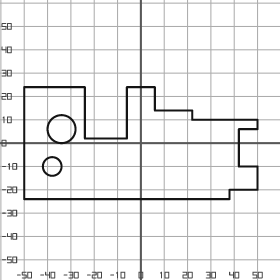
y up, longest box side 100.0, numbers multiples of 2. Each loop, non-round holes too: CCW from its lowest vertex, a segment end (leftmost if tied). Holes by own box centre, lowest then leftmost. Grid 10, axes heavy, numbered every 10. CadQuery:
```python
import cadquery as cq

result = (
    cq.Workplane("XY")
    .moveTo(-50.0, -24.0)
    .lineTo(38.0, -24.0)
    .lineTo(38.0, -20.0)
    .lineTo(50.0, -20.0)
    .lineTo(50.0, -10.0)
    .lineTo(42.0, -10.0)
    .lineTo(42.0, 6.0)
    .lineTo(50.0, 6.0)
    .lineTo(50.0, 10.0)
    .lineTo(22.0, 10.0)
    .lineTo(22.0, 14.0)
    .lineTo(6.0, 14.0)
    .lineTo(6.0, 24.0)
    .lineTo(-6.0, 24.0)
    .lineTo(-6.0, 2.0)
    .lineTo(-24.0, 2.0)
    .lineTo(-24.0, 24.0)
    .lineTo(-50.0, 24.0)
    .close()
    .moveTo(-38.0, -10.0)
    .circle(4.0)
    .moveTo(-34.0, 6.0)
    .circle(6.0)
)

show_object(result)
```